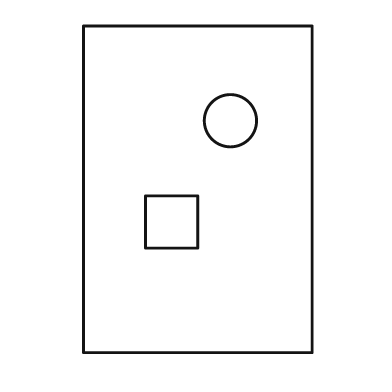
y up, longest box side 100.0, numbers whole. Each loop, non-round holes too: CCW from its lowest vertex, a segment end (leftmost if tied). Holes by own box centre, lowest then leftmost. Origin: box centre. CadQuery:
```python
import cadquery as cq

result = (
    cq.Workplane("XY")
    .moveTo(-35.0, -50.0)
    .lineTo(35.0, -50.0)
    .lineTo(35.0, 50.0)
    .lineTo(-35.0, 50.0)
    .close()
    .moveTo(-16.0, -18.0)
    .lineTo(0.0, -18.0)
    .lineTo(0.0, -2.0)
    .lineTo(-16.0, -2.0)
    .close()
    .moveTo(10.0, 21.0)
    .circle(8.0)
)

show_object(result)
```